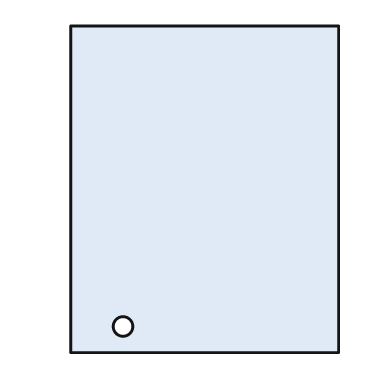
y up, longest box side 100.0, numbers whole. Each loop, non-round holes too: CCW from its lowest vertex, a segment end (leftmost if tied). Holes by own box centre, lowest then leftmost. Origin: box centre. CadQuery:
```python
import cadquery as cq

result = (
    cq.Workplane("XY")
    .moveTo(-41.0, -50.0)
    .lineTo(41.0, -50.0)
    .lineTo(41.0, 50.0)
    .lineTo(-41.0, 50.0)
    .close()
    .moveTo(-25.0, -42.0)
    .circle(3.0)
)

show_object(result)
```